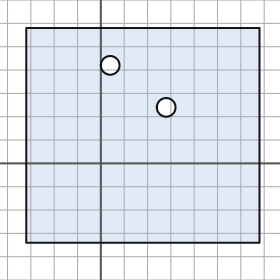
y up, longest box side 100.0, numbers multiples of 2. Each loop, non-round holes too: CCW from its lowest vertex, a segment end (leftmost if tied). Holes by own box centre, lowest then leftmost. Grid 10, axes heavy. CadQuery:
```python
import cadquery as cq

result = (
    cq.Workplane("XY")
    .moveTo(-32.0, -34.0)
    .lineTo(68.0, -34.0)
    .lineTo(68.0, 58.0)
    .lineTo(-32.0, 58.0)
    .close()
    .moveTo(28.0, 24.0)
    .circle(4.0)
    .moveTo(4.0, 42.0)
    .circle(4.0)
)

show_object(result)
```